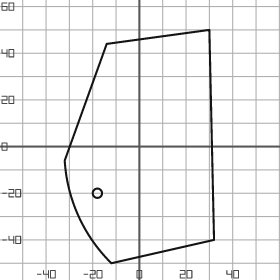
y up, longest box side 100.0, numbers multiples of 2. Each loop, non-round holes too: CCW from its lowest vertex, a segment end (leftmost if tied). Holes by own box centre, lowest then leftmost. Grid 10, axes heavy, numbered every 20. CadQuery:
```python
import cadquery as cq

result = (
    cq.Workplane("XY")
    .moveTo(-12.0, -50.0)
    .lineTo(32.0, -40.0)
    .lineTo(30.0, 50.0)
    .lineTo(-14.0, 44.0)
    .lineTo(-32.0, -6.0)
    .threePointArc((-26.0, -30.0), (-12.0, -50.0))
    .close()
    .moveTo(-18.0, -20.0)
    .circle(2.0)
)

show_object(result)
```